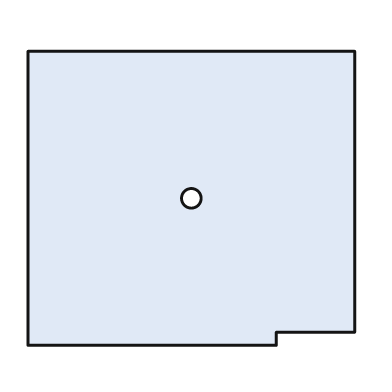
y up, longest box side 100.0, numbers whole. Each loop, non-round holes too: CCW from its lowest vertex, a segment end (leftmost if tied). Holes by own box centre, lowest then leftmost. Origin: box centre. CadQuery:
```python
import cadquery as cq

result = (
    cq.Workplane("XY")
    .moveTo(-50.0, -45.0)
    .lineTo(26.0, -45.0)
    .lineTo(26.0, -41.0)
    .lineTo(50.0, -41.0)
    .lineTo(50.0, 45.0)
    .lineTo(-50.0, 45.0)
    .close()
    .moveTo(0.0, 0.0)
    .circle(3.0)
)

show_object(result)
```